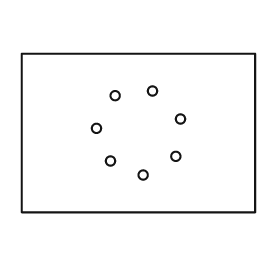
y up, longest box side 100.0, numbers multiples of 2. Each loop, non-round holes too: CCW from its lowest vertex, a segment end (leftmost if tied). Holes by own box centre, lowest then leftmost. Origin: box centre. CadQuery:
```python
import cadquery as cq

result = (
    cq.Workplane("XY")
    .moveTo(-50.0, -34.0)
    .lineTo(50.0, -34.0)
    .lineTo(50.0, 34.0)
    .lineTo(-50.0, 34.0)
    .close()
    .moveTo(2.0, -18.0)
    .circle(2.0)
    .moveTo(-12.0, -12.0)
    .circle(2.0)
    .moveTo(16.0, -10.0)
    .circle(2.0)
    .moveTo(-18.0, 2.0)
    .circle(2.0)
    .moveTo(18.0, 6.0)
    .circle(2.0)
    .moveTo(-10.0, 16.0)
    .circle(2.0)
    .moveTo(6.0, 18.0)
    .circle(2.0)
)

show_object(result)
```